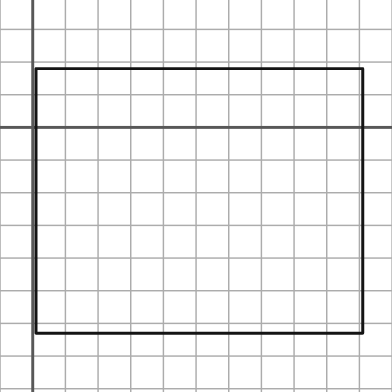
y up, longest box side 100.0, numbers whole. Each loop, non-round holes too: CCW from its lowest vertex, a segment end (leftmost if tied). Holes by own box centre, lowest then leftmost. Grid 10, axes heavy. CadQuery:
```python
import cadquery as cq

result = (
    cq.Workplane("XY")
    .moveTo(1.0, -63.0)
    .lineTo(101.0, -63.0)
    .lineTo(101.0, 18.0)
    .lineTo(1.0, 18.0)
    .close()
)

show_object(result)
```